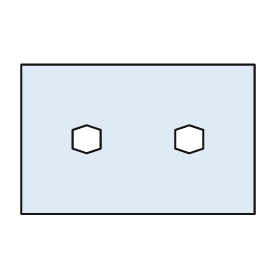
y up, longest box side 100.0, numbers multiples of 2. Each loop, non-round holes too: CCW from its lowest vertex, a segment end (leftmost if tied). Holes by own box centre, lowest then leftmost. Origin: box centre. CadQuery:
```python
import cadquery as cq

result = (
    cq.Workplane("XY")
    .moveTo(-50.0, -32.0)
    .lineTo(50.0, -32.0)
    .lineTo(50.0, 32.0)
    .lineTo(-50.0, 32.0)
    .close()
    .moveTo(-22.0, -6.0)
    .lineTo(-16.0, -4.0)
    .lineTo(-16.0, 4.0)
    .lineTo(-22.0, 6.0)
    .lineTo(-28.0, 4.0)
    .lineTo(-28.0, -4.0)
    .close()
    .moveTo(22.0, -6.0)
    .lineTo(28.0, -4.0)
    .lineTo(28.0, 4.0)
    .lineTo(22.0, 6.0)
    .lineTo(16.0, 4.0)
    .lineTo(16.0, -4.0)
    .close()
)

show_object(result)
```